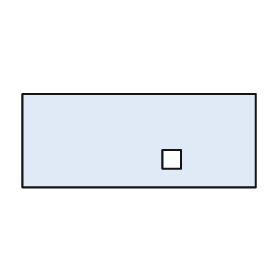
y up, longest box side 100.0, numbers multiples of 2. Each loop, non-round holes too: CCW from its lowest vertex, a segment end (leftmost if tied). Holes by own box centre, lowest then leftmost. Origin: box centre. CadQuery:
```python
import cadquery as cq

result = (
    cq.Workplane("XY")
    .moveTo(-50.0, -20.0)
    .lineTo(50.0, -20.0)
    .lineTo(50.0, 20.0)
    .lineTo(-50.0, 20.0)
    .close()
    .moveTo(10.0, -12.0)
    .lineTo(18.0, -12.0)
    .lineTo(18.0, -4.0)
    .lineTo(10.0, -4.0)
    .close()
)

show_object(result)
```